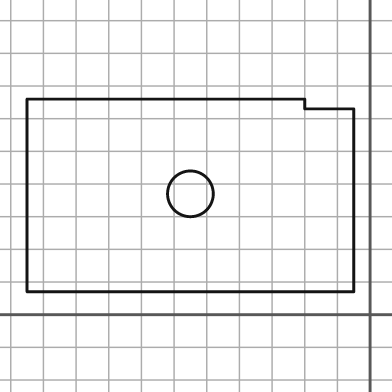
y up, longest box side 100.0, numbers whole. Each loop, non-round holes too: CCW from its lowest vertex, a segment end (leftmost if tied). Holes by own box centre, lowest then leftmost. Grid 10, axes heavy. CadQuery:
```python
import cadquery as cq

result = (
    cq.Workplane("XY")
    .moveTo(-105.0, 7.0)
    .lineTo(-5.0, 7.0)
    .lineTo(-5.0, 63.0)
    .lineTo(-20.0, 63.0)
    .lineTo(-20.0, 66.0)
    .lineTo(-105.0, 66.0)
    .close()
    .moveTo(-55.0, 37.0)
    .circle(7.0)
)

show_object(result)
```